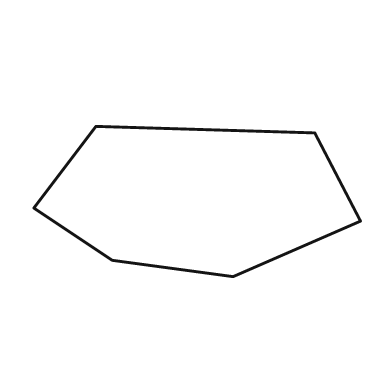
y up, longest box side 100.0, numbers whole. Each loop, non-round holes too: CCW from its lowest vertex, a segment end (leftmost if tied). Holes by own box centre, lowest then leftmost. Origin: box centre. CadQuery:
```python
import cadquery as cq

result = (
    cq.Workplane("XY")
    .moveTo(11.0, -23.0)
    .lineTo(50.0, -6.0)
    .lineTo(36.0, 21.0)
    .lineTo(-31.0, 23.0)
    .lineTo(-50.0, -2.0)
    .lineTo(-26.0, -18.0)
    .close()
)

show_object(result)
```